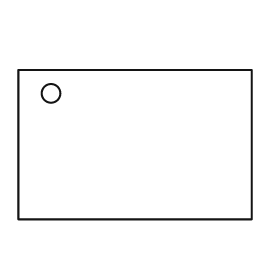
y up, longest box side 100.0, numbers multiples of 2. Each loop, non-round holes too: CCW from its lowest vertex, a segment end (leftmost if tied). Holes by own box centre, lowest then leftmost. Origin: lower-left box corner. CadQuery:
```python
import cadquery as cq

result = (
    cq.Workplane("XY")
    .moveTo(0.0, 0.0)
    .lineTo(100.0, 0.0)
    .lineTo(100.0, 64.0)
    .lineTo(0.0, 64.0)
    .close()
    .moveTo(14.0, 54.0)
    .circle(4.0)
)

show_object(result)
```